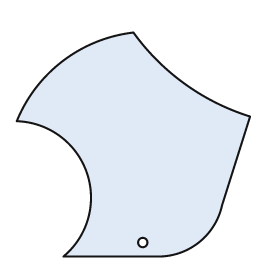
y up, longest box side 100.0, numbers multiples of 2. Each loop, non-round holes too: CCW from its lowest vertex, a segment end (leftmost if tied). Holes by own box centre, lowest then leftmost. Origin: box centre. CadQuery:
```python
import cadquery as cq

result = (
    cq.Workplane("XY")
    .moveTo(-30.0, -48.0)
    .lineTo(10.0, -48.0)
    .threePointArc((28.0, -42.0), (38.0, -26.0))
    .lineTo(50.0, 12.0)
    .threePointArc((22.0, 26.0), (0.0, 48.0))
    .threePointArc((-30.0, 36.0), (-50.0, 10.0))
    .threePointArc((-20.0, -12.0), (-30.0, -48.0))
    .close()
    .moveTo(4.0, -42.0)
    .circle(2.0)
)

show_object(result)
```